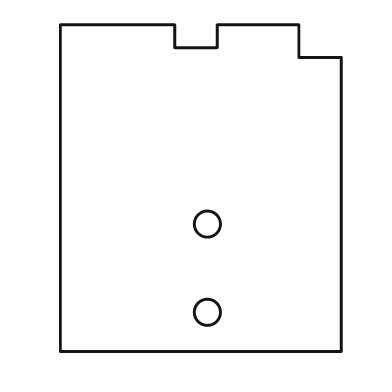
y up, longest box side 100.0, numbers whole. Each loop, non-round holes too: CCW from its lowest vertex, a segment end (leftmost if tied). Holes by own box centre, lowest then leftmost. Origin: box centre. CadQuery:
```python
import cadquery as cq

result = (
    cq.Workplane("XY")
    .moveTo(-43.0, -50.0)
    .lineTo(43.0, -50.0)
    .lineTo(43.0, 40.0)
    .lineTo(30.0, 40.0)
    .lineTo(30.0, 50.0)
    .lineTo(5.0, 50.0)
    .lineTo(5.0, 43.0)
    .lineTo(-8.0, 43.0)
    .lineTo(-8.0, 50.0)
    .lineTo(-43.0, 50.0)
    .close()
    .moveTo(2.0, -38.0)
    .circle(4.0)
    .moveTo(2.0, -11.0)
    .circle(4.0)
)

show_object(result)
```